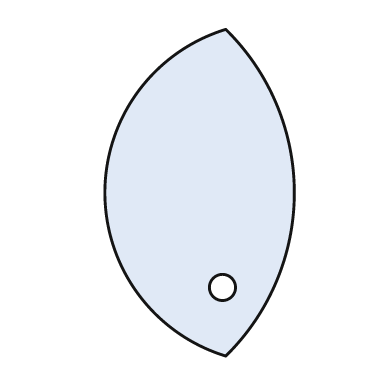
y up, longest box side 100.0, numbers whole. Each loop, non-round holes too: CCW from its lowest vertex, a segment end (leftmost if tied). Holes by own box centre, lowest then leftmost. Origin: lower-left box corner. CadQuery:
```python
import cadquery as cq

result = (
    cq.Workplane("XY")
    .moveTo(37.0, 0.0)
    .threePointArc((58.0, 50.0), (37.0, 100.0))
    .threePointArc((0.0, 50.0), (37.0, 0.0))
    .close()
    .moveTo(36.0, 21.0)
    .circle(4.0)
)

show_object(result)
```